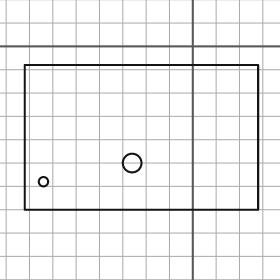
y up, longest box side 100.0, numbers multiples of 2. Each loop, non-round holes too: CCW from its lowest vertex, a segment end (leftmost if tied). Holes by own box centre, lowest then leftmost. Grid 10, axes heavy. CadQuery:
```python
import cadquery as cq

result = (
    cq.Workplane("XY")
    .moveTo(-72.0, -70.0)
    .lineTo(28.0, -70.0)
    .lineTo(28.0, -8.0)
    .lineTo(-72.0, -8.0)
    .close()
    .moveTo(-64.0, -58.0)
    .circle(2.0)
    .moveTo(-26.0, -50.0)
    .circle(4.0)
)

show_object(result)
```